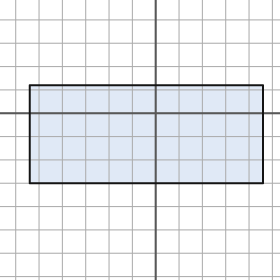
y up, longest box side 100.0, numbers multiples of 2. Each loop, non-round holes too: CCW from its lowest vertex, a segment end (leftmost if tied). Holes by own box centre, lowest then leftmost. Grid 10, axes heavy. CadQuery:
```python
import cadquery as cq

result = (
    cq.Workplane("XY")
    .moveTo(-54.0, -30.0)
    .lineTo(46.0, -30.0)
    .lineTo(46.0, 12.0)
    .lineTo(-54.0, 12.0)
    .close()
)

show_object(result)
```